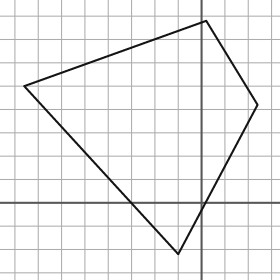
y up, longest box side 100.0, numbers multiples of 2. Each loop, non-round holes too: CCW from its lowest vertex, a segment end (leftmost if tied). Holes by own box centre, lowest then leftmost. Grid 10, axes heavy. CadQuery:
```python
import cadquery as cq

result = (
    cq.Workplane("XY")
    .moveTo(-10.0, -22.0)
    .lineTo(24.0, 42.0)
    .lineTo(2.0, 78.0)
    .lineTo(-76.0, 50.0)
    .close()
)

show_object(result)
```